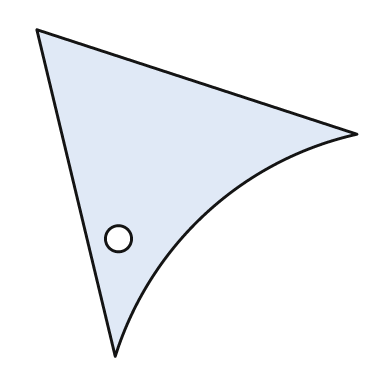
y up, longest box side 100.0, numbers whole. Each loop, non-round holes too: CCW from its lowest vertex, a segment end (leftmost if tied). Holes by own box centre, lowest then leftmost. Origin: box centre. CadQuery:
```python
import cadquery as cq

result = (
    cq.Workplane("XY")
    .moveTo(-25.0, -50.0)
    .threePointArc((3.0, -6.0), (49.0, 18.0))
    .lineTo(-49.0, 50.0)
    .close()
    .moveTo(-24.0, -14.0)
    .circle(4.0)
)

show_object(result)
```